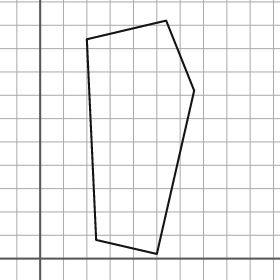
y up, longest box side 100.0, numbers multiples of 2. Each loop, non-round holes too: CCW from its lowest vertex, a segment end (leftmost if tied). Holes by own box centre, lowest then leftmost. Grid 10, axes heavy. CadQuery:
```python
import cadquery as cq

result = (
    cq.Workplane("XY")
    .moveTo(50.0, 2.0)
    .lineTo(66.0, 72.0)
    .lineTo(54.0, 102.0)
    .lineTo(20.0, 94.0)
    .lineTo(24.0, 8.0)
    .close()
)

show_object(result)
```